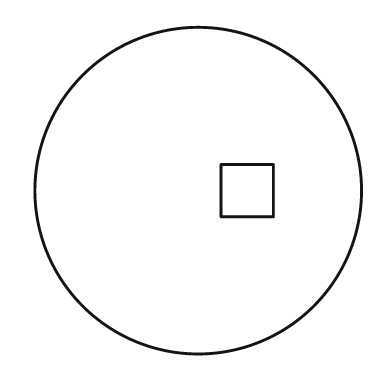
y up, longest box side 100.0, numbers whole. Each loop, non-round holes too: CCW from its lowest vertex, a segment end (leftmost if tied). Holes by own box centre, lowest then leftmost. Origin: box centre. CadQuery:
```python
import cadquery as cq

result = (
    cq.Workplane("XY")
    .moveTo(0.0, 0.0)
    .circle(50.0)
    .moveTo(7.0, -8.0)
    .lineTo(23.0, -8.0)
    .lineTo(23.0, 8.0)
    .lineTo(7.0, 8.0)
    .close()
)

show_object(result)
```